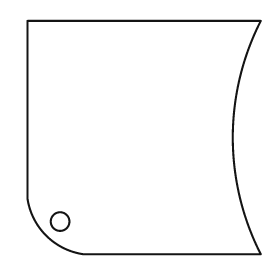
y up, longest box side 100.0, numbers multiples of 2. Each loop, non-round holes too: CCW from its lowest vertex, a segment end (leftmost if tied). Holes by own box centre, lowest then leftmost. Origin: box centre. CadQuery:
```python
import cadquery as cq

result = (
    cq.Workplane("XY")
    .moveTo(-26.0, -50.0)
    .lineTo(50.0, -50.0)
    .threePointArc((38.0, 0.0), (50.0, 50.0))
    .lineTo(-50.0, 50.0)
    .lineTo(-50.0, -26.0)
    .threePointArc((-42.0, -42.0), (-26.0, -50.0))
    .close()
    .moveTo(-36.0, -36.0)
    .circle(4.0)
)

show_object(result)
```